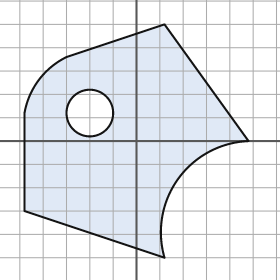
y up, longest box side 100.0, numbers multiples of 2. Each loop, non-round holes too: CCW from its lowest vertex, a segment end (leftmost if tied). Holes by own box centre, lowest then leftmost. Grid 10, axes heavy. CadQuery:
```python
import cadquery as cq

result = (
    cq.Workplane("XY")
    .moveTo(12.0, -50.0)
    .threePointArc((18.0, -16.0), (48.0, 0.0))
    .lineTo(12.0, 50.0)
    .lineTo(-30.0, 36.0)
    .threePointArc((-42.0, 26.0), (-48.0, 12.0))
    .lineTo(-48.0, -30.0)
    .close()
    .moveTo(-20.0, 12.0)
    .circle(10.0)
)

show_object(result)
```